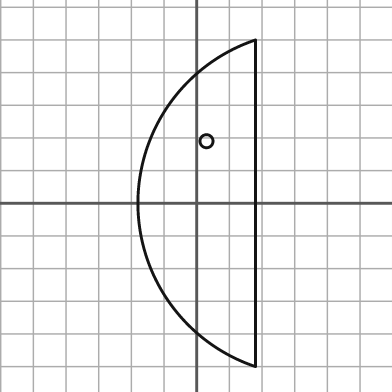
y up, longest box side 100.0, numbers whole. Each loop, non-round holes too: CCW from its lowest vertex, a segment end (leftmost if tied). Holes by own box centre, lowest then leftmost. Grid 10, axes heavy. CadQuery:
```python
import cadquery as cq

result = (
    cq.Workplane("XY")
    .moveTo(18.0, -50.0)
    .lineTo(18.0, 50.0)
    .threePointArc((-18.0, 0.0), (18.0, -50.0))
    .close()
    .moveTo(3.0, 19.0)
    .circle(2.0)
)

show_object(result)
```